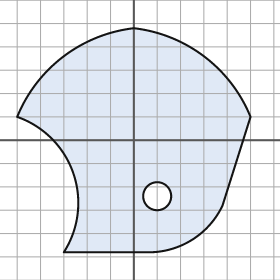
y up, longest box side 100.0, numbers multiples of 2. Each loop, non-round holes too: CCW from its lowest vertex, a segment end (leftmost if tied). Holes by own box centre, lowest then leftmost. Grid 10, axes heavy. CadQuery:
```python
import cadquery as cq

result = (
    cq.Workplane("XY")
    .moveTo(-30.0, -48.0)
    .lineTo(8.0, -48.0)
    .threePointArc((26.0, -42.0), (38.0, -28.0))
    .lineTo(50.0, 10.0)
    .threePointArc((30.0, 36.0), (0.0, 48.0))
    .threePointArc((-30.0, 36.0), (-50.0, 10.0))
    .threePointArc((-26.0, -14.0), (-30.0, -48.0))
    .close()
    .moveTo(10.0, -24.0)
    .circle(6.0)
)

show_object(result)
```